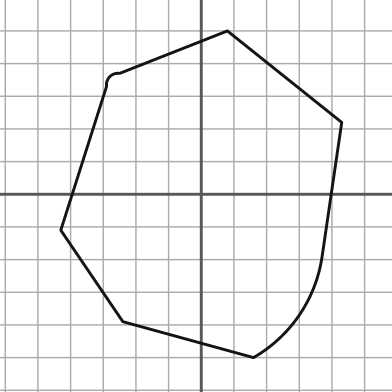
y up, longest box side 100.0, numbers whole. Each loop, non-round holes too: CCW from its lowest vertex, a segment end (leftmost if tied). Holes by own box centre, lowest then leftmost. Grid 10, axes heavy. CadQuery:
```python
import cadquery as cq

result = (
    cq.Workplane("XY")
    .moveTo(16.0, -50.0)
    .threePointArc((30.0, -37.0), (37.0, -19.0))
    .lineTo(43.0, 22.0)
    .lineTo(8.0, 50.0)
    .lineTo(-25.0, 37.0)
    .threePointArc((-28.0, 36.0), (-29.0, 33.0))
    .lineTo(-43.0, -11.0)
    .lineTo(-24.0, -39.0)
    .close()
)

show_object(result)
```